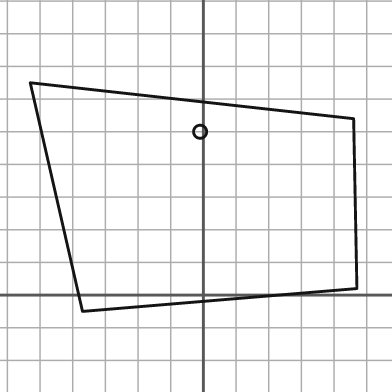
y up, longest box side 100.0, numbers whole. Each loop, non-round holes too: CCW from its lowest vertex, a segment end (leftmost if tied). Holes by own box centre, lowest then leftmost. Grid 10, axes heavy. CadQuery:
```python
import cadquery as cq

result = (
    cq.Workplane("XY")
    .moveTo(-37.0, -5.0)
    .lineTo(47.0, 2.0)
    .lineTo(46.0, 54.0)
    .lineTo(-53.0, 65.0)
    .close()
    .moveTo(-1.0, 50.0)
    .circle(2.0)
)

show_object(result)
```